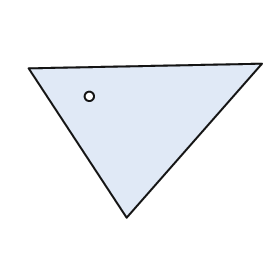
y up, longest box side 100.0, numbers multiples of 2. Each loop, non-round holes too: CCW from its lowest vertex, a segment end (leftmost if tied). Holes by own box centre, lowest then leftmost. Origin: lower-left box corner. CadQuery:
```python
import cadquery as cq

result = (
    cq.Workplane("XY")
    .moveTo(42.0, 0.0)
    .lineTo(100.0, 66.0)
    .lineTo(0.0, 64.0)
    .close()
    .moveTo(26.0, 52.0)
    .circle(2.0)
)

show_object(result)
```